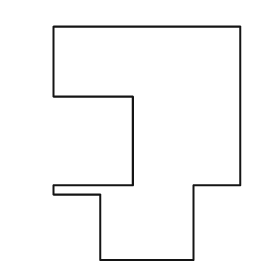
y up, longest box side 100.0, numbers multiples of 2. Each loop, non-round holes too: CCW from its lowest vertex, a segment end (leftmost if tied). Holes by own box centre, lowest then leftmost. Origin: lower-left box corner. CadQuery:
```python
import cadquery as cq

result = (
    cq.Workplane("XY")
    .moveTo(20.0, 0.0)
    .lineTo(60.0, 0.0)
    .lineTo(60.0, 32.0)
    .lineTo(80.0, 32.0)
    .lineTo(80.0, 100.0)
    .lineTo(0.0, 100.0)
    .lineTo(0.0, 70.0)
    .lineTo(34.0, 70.0)
    .lineTo(34.0, 32.0)
    .lineTo(0.0, 32.0)
    .lineTo(0.0, 28.0)
    .lineTo(20.0, 28.0)
    .close()
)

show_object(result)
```